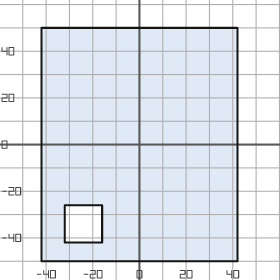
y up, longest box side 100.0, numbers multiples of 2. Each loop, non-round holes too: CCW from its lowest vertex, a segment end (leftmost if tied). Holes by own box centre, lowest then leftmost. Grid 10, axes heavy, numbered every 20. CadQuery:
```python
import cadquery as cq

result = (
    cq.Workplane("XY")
    .moveTo(-42.0, -50.0)
    .lineTo(42.0, -50.0)
    .lineTo(42.0, 50.0)
    .lineTo(-42.0, 50.0)
    .close()
    .moveTo(-32.0, -42.0)
    .lineTo(-16.0, -42.0)
    .lineTo(-16.0, -26.0)
    .lineTo(-32.0, -26.0)
    .close()
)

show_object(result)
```